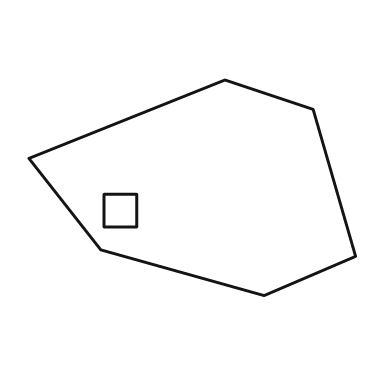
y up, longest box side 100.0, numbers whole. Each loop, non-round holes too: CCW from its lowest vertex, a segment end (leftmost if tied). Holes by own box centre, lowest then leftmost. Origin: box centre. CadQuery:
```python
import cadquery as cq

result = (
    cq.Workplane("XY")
    .moveTo(22.0, -33.0)
    .lineTo(50.0, -21.0)
    .lineTo(37.0, 24.0)
    .lineTo(10.0, 33.0)
    .lineTo(-50.0, 9.0)
    .lineTo(-28.0, -19.0)
    .close()
    .moveTo(-27.0, -12.0)
    .lineTo(-17.0, -12.0)
    .lineTo(-17.0, -2.0)
    .lineTo(-27.0, -2.0)
    .close()
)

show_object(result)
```